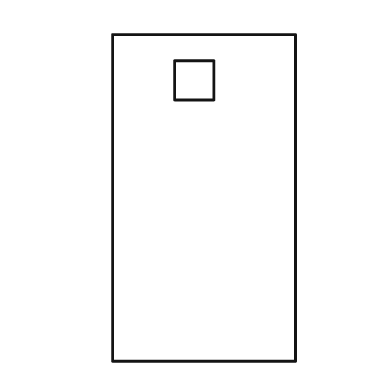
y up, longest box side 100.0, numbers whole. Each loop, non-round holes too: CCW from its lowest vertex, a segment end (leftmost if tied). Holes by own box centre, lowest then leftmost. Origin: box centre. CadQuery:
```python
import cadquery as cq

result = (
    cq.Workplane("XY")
    .moveTo(-28.0, -50.0)
    .lineTo(28.0, -50.0)
    .lineTo(28.0, 50.0)
    .lineTo(-28.0, 50.0)
    .close()
    .moveTo(-9.0, 30.0)
    .lineTo(3.0, 30.0)
    .lineTo(3.0, 42.0)
    .lineTo(-9.0, 42.0)
    .close()
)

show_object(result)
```